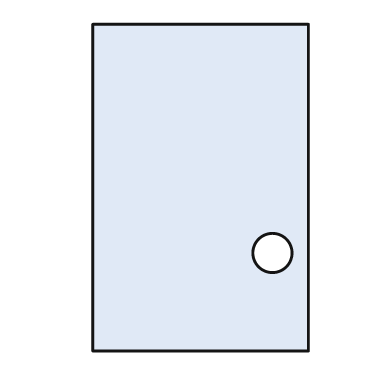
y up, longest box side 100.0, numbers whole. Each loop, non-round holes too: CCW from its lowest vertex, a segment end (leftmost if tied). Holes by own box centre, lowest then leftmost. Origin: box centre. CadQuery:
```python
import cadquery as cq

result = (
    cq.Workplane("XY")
    .moveTo(-33.0, -50.0)
    .lineTo(33.0, -50.0)
    .lineTo(33.0, 50.0)
    .lineTo(-33.0, 50.0)
    .close()
    .moveTo(22.0, -20.0)
    .circle(6.0)
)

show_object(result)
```